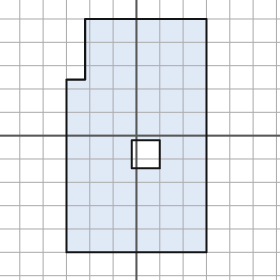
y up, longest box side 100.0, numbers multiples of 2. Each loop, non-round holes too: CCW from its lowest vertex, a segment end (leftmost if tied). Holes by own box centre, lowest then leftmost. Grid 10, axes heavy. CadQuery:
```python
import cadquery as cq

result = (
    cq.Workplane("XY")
    .moveTo(-30.0, -50.0)
    .lineTo(30.0, -50.0)
    .lineTo(30.0, 50.0)
    .lineTo(-22.0, 50.0)
    .lineTo(-22.0, 24.0)
    .lineTo(-30.0, 24.0)
    .close()
    .moveTo(-2.0, -14.0)
    .lineTo(10.0, -14.0)
    .lineTo(10.0, -2.0)
    .lineTo(-2.0, -2.0)
    .close()
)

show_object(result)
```